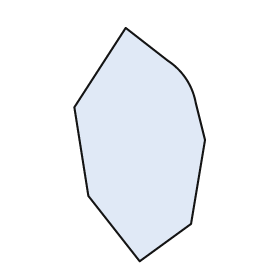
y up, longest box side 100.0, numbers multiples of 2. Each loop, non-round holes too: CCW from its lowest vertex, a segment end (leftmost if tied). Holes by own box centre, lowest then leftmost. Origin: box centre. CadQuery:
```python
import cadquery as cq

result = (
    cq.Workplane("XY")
    .moveTo(0.0, -50.0)
    .lineTo(22.0, -34.0)
    .lineTo(28.0, 2.0)
    .lineTo(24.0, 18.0)
    .threePointArc((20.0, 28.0), (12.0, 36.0))
    .lineTo(-6.0, 50.0)
    .lineTo(-28.0, 16.0)
    .lineTo(-22.0, -22.0)
    .close()
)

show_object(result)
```